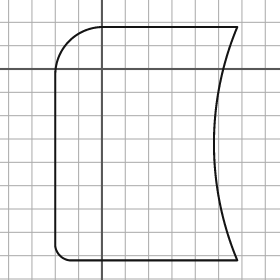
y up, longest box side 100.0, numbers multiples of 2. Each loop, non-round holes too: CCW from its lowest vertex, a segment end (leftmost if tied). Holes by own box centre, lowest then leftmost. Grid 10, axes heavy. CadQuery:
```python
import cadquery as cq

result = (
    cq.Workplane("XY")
    .moveTo(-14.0, -82.0)
    .lineTo(58.0, -82.0)
    .threePointArc((48.0, -32.0), (58.0, 18.0))
    .lineTo(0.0, 18.0)
    .threePointArc((-14.0, 12.0), (-20.0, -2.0))
    .lineTo(-20.0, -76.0)
    .threePointArc((-18.0, -80.0), (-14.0, -82.0))
    .close()
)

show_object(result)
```